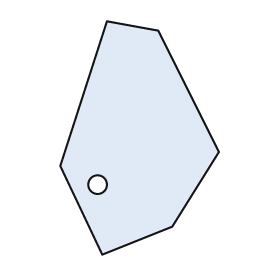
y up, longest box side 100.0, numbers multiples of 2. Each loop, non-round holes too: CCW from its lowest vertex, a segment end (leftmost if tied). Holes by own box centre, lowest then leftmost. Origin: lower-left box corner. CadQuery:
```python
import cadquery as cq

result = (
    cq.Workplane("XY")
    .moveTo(18.0, 0.0)
    .lineTo(48.0, 12.0)
    .lineTo(68.0, 44.0)
    .lineTo(42.0, 96.0)
    .lineTo(20.0, 100.0)
    .lineTo(0.0, 38.0)
    .close()
    .moveTo(16.0, 30.0)
    .circle(4.0)
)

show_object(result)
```